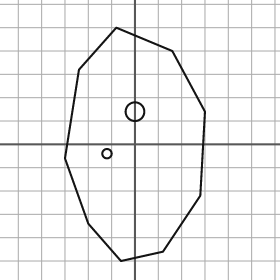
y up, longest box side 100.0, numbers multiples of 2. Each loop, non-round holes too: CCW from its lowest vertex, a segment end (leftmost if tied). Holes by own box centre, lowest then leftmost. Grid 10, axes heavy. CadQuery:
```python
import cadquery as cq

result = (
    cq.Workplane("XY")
    .moveTo(-6.0, -50.0)
    .lineTo(12.0, -46.0)
    .lineTo(28.0, -22.0)
    .lineTo(30.0, 14.0)
    .lineTo(16.0, 40.0)
    .lineTo(-8.0, 50.0)
    .lineTo(-24.0, 32.0)
    .lineTo(-30.0, -6.0)
    .lineTo(-20.0, -34.0)
    .close()
    .moveTo(-12.0, -4.0)
    .circle(2.0)
    .moveTo(0.0, 14.0)
    .circle(4.0)
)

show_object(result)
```